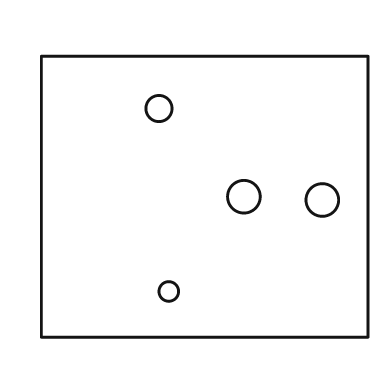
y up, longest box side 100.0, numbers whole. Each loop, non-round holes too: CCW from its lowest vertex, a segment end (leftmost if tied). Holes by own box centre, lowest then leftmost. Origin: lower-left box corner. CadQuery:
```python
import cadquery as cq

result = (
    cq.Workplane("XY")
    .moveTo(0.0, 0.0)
    .lineTo(100.0, 0.0)
    .lineTo(100.0, 86.0)
    .lineTo(0.0, 86.0)
    .close()
    .moveTo(39.0, 14.0)
    .circle(3.0)
    .moveTo(86.0, 42.0)
    .circle(5.0)
    .moveTo(62.0, 43.0)
    .circle(5.0)
    .moveTo(36.0, 70.0)
    .circle(4.0)
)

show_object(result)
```